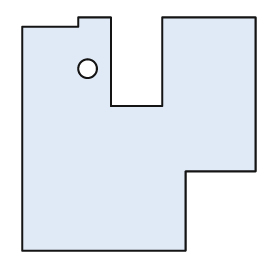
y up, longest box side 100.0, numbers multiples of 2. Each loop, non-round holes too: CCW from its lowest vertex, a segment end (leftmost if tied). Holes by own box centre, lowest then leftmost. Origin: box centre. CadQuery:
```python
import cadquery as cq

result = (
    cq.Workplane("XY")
    .moveTo(-50.0, -50.0)
    .lineTo(20.0, -50.0)
    .lineTo(20.0, -16.0)
    .lineTo(50.0, -16.0)
    .lineTo(50.0, 50.0)
    .lineTo(10.0, 50.0)
    .lineTo(10.0, 12.0)
    .lineTo(-12.0, 12.0)
    .lineTo(-12.0, 50.0)
    .lineTo(-26.0, 50.0)
    .lineTo(-26.0, 46.0)
    .lineTo(-50.0, 46.0)
    .close()
    .moveTo(-22.0, 28.0)
    .circle(4.0)
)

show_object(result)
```